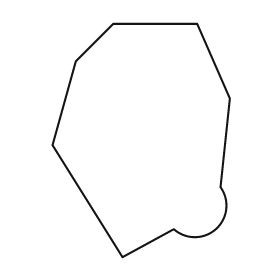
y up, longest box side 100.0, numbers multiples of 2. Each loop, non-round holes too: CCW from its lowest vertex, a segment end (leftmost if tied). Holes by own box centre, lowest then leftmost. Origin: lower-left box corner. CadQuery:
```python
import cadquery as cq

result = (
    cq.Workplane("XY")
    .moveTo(30.0, 0.0)
    .lineTo(52.0, 12.0)
    .threePointArc((70.0, 12.0), (72.0, 30.0))
    .lineTo(76.0, 68.0)
    .lineTo(62.0, 100.0)
    .lineTo(26.0, 100.0)
    .lineTo(10.0, 84.0)
    .lineTo(0.0, 48.0)
    .close()
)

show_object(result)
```